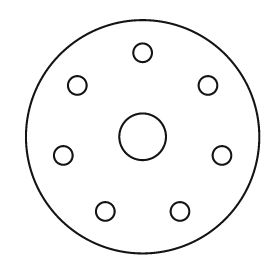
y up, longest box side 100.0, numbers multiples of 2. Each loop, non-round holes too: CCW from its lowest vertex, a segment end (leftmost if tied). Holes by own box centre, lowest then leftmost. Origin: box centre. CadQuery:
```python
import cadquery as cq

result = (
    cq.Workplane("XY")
    .moveTo(0.0, 0.0)
    .circle(50.0)
    .moveTo(-16.0, -32.0)
    .circle(4.0)
    .moveTo(16.0, -32.0)
    .circle(4.0)
    .moveTo(-34.0, -8.0)
    .circle(4.0)
    .moveTo(34.0, -8.0)
    .circle(4.0)
    .moveTo(0.0, 0.0)
    .circle(10.0)
    .moveTo(-28.0, 22.0)
    .circle(4.0)
    .moveTo(28.0, 22.0)
    .circle(4.0)
    .moveTo(0.0, 36.0)
    .circle(4.0)
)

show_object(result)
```